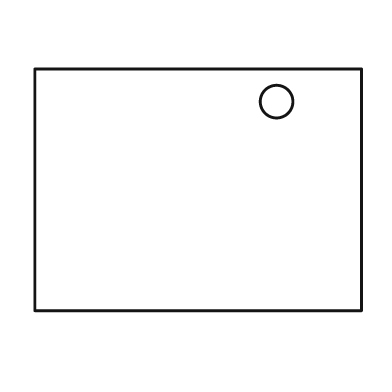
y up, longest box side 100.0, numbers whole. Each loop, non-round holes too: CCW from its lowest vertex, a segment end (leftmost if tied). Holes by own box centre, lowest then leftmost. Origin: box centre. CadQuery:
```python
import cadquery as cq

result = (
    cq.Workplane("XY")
    .moveTo(-50.0, -37.0)
    .lineTo(50.0, -37.0)
    .lineTo(50.0, 37.0)
    .lineTo(-50.0, 37.0)
    .close()
    .moveTo(24.0, 27.0)
    .circle(5.0)
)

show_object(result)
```